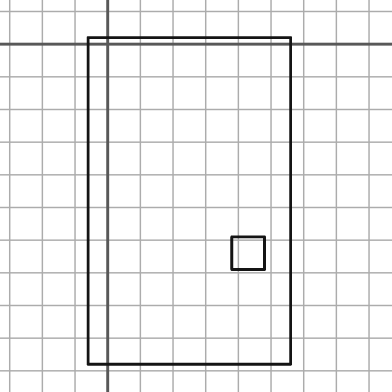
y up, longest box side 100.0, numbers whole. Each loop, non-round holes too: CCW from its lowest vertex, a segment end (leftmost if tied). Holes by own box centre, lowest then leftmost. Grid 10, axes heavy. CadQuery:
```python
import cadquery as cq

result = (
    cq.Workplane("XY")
    .moveTo(-6.0, -98.0)
    .lineTo(56.0, -98.0)
    .lineTo(56.0, 2.0)
    .lineTo(-6.0, 2.0)
    .close()
    .moveTo(38.0, -69.0)
    .lineTo(48.0, -69.0)
    .lineTo(48.0, -59.0)
    .lineTo(38.0, -59.0)
    .close()
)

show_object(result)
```